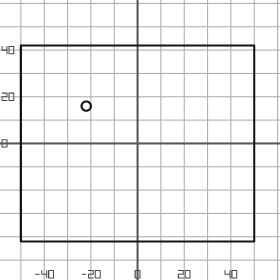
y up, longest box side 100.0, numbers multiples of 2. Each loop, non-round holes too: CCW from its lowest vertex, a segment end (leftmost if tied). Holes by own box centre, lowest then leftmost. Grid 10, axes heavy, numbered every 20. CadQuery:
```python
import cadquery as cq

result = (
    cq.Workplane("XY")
    .moveTo(-50.0, -42.0)
    .lineTo(50.0, -42.0)
    .lineTo(50.0, 42.0)
    .lineTo(-50.0, 42.0)
    .close()
    .moveTo(-22.0, 16.0)
    .circle(2.0)
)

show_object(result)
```